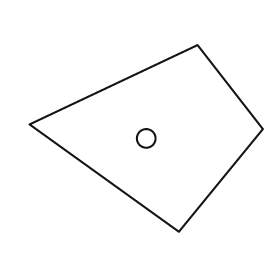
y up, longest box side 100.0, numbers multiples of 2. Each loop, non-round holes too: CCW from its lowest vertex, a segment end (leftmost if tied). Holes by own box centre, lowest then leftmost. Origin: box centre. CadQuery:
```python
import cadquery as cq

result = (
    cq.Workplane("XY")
    .moveTo(14.0, -40.0)
    .lineTo(50.0, 4.0)
    .lineTo(22.0, 40.0)
    .lineTo(-50.0, 6.0)
    .close()
    .moveTo(0.0, 0.0)
    .circle(4.0)
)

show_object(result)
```